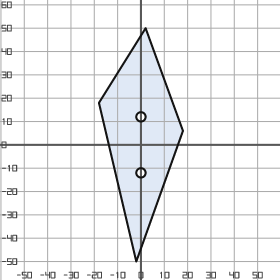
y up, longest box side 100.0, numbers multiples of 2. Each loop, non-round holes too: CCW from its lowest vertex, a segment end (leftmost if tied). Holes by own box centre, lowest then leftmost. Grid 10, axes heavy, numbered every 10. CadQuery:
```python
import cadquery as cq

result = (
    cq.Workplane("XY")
    .moveTo(-2.0, -50.0)
    .lineTo(18.0, 6.0)
    .lineTo(2.0, 50.0)
    .lineTo(-18.0, 18.0)
    .close()
    .moveTo(0.0, -12.0)
    .circle(2.0)
    .moveTo(0.0, 12.0)
    .circle(2.0)
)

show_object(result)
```